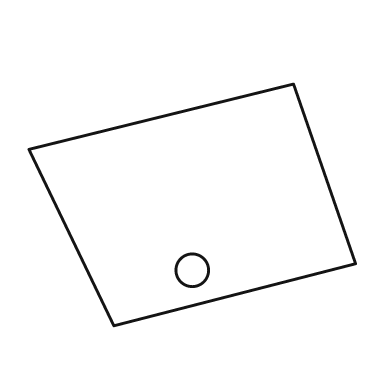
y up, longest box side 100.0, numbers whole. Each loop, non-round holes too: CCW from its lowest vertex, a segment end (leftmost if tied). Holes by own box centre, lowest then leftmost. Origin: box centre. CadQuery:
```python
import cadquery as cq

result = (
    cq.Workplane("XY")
    .moveTo(-24.0, -37.0)
    .lineTo(50.0, -18.0)
    .lineTo(31.0, 37.0)
    .lineTo(-50.0, 17.0)
    .close()
    .moveTo(0.0, -20.0)
    .circle(5.0)
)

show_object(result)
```